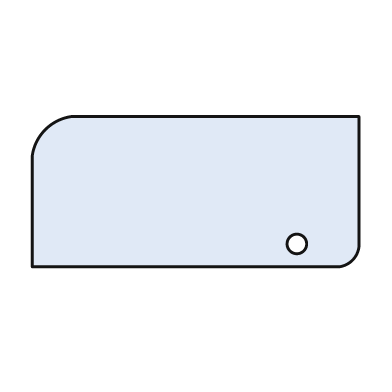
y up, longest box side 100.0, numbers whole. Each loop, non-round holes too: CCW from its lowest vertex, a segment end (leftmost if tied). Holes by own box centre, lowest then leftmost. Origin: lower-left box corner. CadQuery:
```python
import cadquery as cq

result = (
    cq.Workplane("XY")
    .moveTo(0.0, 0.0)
    .lineTo(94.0, 0.0)
    .threePointArc((98.0, 2.0), (100.0, 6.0))
    .lineTo(100.0, 46.0)
    .lineTo(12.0, 46.0)
    .threePointArc((4.0, 42.0), (0.0, 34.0))
    .close()
    .moveTo(81.0, 7.0)
    .circle(3.0)
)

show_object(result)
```